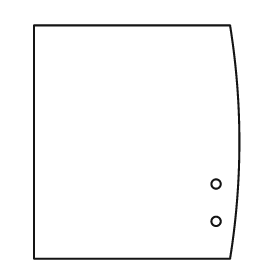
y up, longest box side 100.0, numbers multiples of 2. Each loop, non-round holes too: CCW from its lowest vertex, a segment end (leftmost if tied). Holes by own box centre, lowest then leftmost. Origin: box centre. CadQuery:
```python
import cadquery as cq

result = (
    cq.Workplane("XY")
    .moveTo(-44.0, -50.0)
    .lineTo(40.0, -50.0)
    .threePointArc((44.0, 0.0), (40.0, 50.0))
    .lineTo(-44.0, 50.0)
    .close()
    .moveTo(34.0, -34.0)
    .circle(2.0)
    .moveTo(34.0, -18.0)
    .circle(2.0)
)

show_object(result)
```